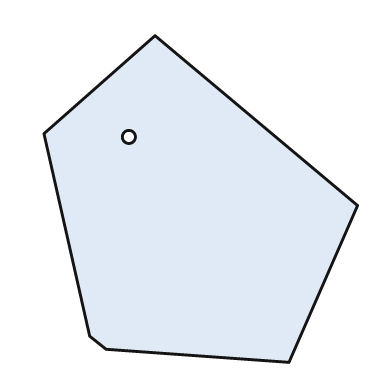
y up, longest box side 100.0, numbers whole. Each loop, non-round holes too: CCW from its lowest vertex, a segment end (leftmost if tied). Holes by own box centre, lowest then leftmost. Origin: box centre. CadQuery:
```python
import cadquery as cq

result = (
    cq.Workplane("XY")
    .moveTo(27.0, -50.0)
    .lineTo(48.0, -2.0)
    .lineTo(-14.0, 50.0)
    .lineTo(-48.0, 20.0)
    .lineTo(-34.0, -42.0)
    .lineTo(-29.0, -46.0)
    .close()
    .moveTo(-22.0, 19.0)
    .circle(2.0)
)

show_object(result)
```